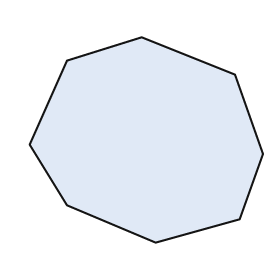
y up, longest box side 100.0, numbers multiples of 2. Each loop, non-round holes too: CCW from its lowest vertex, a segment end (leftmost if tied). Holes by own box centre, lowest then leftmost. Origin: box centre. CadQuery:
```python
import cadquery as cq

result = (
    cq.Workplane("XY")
    .moveTo(4.0, -44.0)
    .lineTo(40.0, -34.0)
    .lineTo(50.0, -6.0)
    .lineTo(38.0, 28.0)
    .lineTo(-2.0, 44.0)
    .lineTo(-34.0, 34.0)
    .lineTo(-50.0, -2.0)
    .lineTo(-34.0, -28.0)
    .close()
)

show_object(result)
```